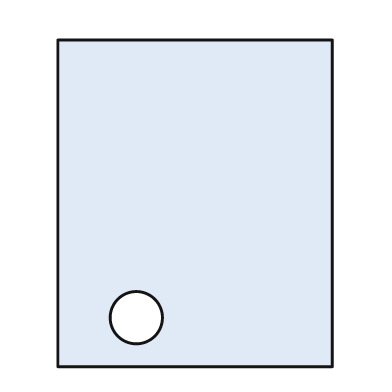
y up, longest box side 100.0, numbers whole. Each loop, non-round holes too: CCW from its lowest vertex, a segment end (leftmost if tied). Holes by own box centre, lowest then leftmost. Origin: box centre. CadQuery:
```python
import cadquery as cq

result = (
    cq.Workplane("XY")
    .moveTo(-42.0, -50.0)
    .lineTo(42.0, -50.0)
    .lineTo(42.0, 50.0)
    .lineTo(-42.0, 50.0)
    .close()
    .moveTo(-18.0, -35.0)
    .circle(8.0)
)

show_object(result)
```